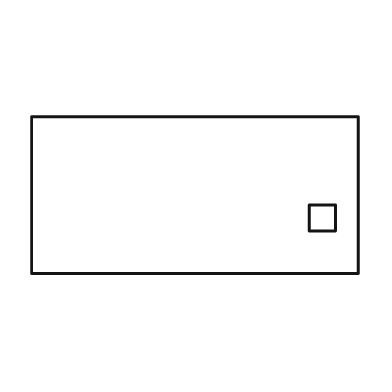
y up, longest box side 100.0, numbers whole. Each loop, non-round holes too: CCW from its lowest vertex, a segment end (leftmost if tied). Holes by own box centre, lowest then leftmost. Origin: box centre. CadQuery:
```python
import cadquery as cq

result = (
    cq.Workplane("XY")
    .moveTo(-50.0, -24.0)
    .lineTo(50.0, -24.0)
    .lineTo(50.0, 24.0)
    .lineTo(-50.0, 24.0)
    .close()
    .moveTo(35.0, -11.0)
    .lineTo(43.0, -11.0)
    .lineTo(43.0, -3.0)
    .lineTo(35.0, -3.0)
    .close()
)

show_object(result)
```